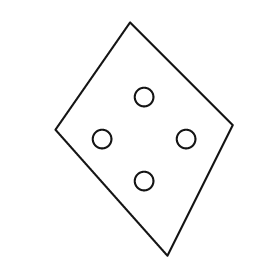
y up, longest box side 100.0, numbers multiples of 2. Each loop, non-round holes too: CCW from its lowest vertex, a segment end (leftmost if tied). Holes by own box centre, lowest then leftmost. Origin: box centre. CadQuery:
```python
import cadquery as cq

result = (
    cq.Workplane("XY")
    .moveTo(10.0, -50.0)
    .lineTo(38.0, 6.0)
    .lineTo(-6.0, 50.0)
    .lineTo(-38.0, 4.0)
    .close()
    .moveTo(0.0, -18.0)
    .circle(4.0)
    .moveTo(-18.0, 0.0)
    .circle(4.0)
    .moveTo(18.0, 0.0)
    .circle(4.0)
    .moveTo(0.0, 18.0)
    .circle(4.0)
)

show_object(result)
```